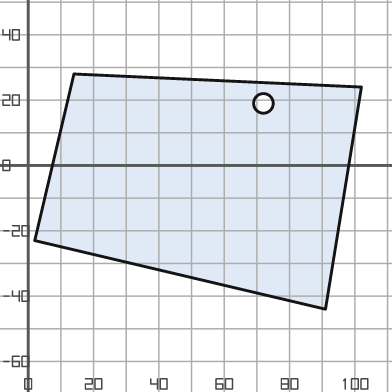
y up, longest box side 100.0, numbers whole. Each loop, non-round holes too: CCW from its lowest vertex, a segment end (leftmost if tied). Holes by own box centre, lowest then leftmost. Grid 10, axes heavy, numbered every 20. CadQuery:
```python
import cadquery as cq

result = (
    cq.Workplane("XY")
    .moveTo(91.0, -44.0)
    .lineTo(102.0, 24.0)
    .lineTo(14.0, 28.0)
    .lineTo(2.0, -23.0)
    .close()
    .moveTo(72.0, 19.0)
    .circle(3.0)
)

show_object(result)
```